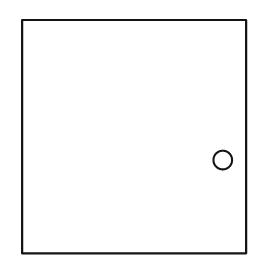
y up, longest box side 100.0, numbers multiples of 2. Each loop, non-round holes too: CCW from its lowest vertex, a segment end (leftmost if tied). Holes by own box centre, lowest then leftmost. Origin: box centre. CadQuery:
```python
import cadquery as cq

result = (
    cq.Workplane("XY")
    .moveTo(-48.0, -50.0)
    .lineTo(48.0, -50.0)
    .lineTo(48.0, 50.0)
    .lineTo(-48.0, 50.0)
    .close()
    .moveTo(38.0, -10.0)
    .circle(4.0)
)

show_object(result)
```